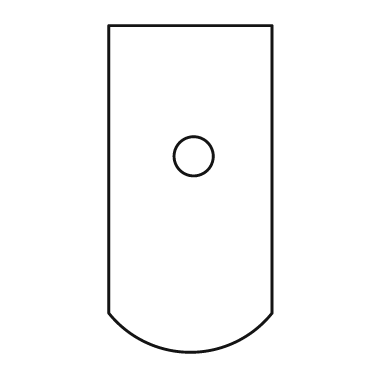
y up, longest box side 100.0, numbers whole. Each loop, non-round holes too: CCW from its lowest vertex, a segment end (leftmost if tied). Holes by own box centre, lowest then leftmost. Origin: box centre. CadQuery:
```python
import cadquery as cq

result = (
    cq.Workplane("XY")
    .moveTo(-25.0, -38.0)
    .threePointArc((0.0, -50.0), (25.0, -38.0))
    .lineTo(25.0, 50.0)
    .lineTo(-25.0, 50.0)
    .close()
    .moveTo(1.0, 10.0)
    .circle(6.0)
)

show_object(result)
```